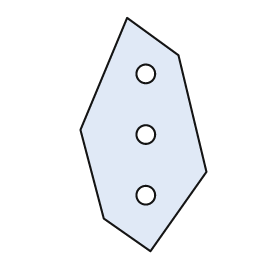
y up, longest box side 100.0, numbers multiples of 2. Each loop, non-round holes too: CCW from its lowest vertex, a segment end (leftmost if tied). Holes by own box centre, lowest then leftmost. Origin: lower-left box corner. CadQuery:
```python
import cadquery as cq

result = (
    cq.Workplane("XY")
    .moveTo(30.0, 0.0)
    .lineTo(54.0, 34.0)
    .lineTo(42.0, 84.0)
    .lineTo(20.0, 100.0)
    .lineTo(0.0, 52.0)
    .lineTo(10.0, 14.0)
    .close()
    .moveTo(28.0, 24.0)
    .circle(4.0)
    .moveTo(28.0, 50.0)
    .circle(4.0)
    .moveTo(28.0, 76.0)
    .circle(4.0)
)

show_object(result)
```